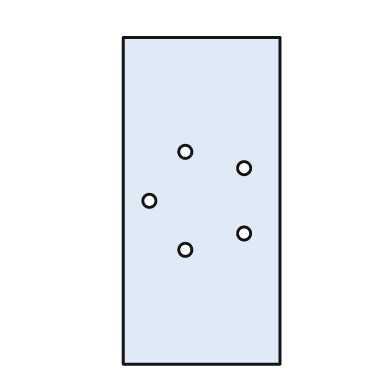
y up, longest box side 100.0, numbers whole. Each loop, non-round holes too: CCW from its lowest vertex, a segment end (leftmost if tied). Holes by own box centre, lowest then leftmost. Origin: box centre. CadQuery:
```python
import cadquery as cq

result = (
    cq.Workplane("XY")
    .moveTo(-24.0, -50.0)
    .lineTo(24.0, -50.0)
    .lineTo(24.0, 50.0)
    .lineTo(-24.0, 50.0)
    .close()
    .moveTo(-5.0, -15.0)
    .circle(2.0)
    .moveTo(13.0, -10.0)
    .circle(2.0)
    .moveTo(-16.0, 0.0)
    .circle(2.0)
    .moveTo(13.0, 10.0)
    .circle(2.0)
    .moveTo(-5.0, 15.0)
    .circle(2.0)
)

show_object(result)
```